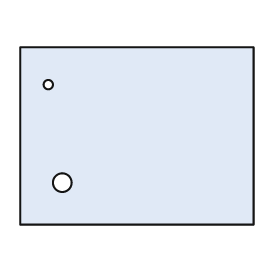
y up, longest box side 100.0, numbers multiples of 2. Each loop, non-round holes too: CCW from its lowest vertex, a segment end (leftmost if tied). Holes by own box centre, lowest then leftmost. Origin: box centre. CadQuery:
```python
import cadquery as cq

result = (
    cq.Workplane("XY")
    .moveTo(-50.0, -38.0)
    .lineTo(50.0, -38.0)
    .lineTo(50.0, 38.0)
    .lineTo(-50.0, 38.0)
    .close()
    .moveTo(-32.0, -20.0)
    .circle(4.0)
    .moveTo(-38.0, 22.0)
    .circle(2.0)
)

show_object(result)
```